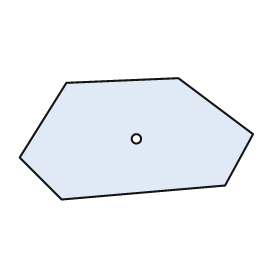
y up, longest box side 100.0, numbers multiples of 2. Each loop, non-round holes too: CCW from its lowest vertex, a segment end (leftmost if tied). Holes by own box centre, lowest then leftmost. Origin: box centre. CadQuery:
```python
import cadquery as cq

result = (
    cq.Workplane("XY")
    .moveTo(-32.0, -26.0)
    .lineTo(38.0, -20.0)
    .lineTo(50.0, 2.0)
    .lineTo(18.0, 26.0)
    .lineTo(-30.0, 24.0)
    .lineTo(-50.0, -8.0)
    .close()
    .moveTo(0.0, 0.0)
    .circle(2.0)
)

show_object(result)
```